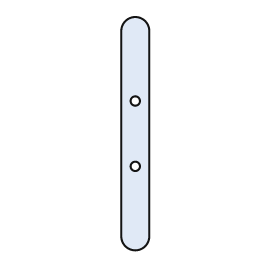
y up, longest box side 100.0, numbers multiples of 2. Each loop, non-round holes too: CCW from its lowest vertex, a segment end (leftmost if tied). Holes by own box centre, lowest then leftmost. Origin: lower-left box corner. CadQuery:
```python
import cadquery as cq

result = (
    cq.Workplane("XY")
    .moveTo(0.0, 6.0)
    .threePointArc((6.0, 0.0), (12.0, 6.0))
    .lineTo(12.0, 94.0)
    .threePointArc((6.0, 100.0), (0.0, 94.0))
    .close()
    .moveTo(6.0, 36.0)
    .circle(2.0)
    .moveTo(6.0, 64.0)
    .circle(2.0)
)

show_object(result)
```